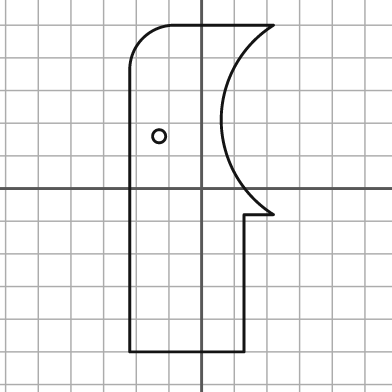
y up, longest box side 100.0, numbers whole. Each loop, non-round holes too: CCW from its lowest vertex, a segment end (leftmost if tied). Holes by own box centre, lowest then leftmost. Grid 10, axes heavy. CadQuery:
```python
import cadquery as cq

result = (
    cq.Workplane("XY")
    .moveTo(-22.0, -50.0)
    .lineTo(13.0, -50.0)
    .lineTo(13.0, -8.0)
    .lineTo(22.0, -8.0)
    .threePointArc((6.0, 21.0), (22.0, 50.0))
    .lineTo(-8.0, 50.0)
    .threePointArc((-18.0, 46.0), (-22.0, 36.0))
    .close()
    .moveTo(-13.0, 16.0)
    .circle(2.0)
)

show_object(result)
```